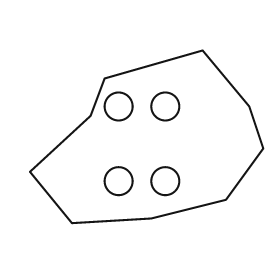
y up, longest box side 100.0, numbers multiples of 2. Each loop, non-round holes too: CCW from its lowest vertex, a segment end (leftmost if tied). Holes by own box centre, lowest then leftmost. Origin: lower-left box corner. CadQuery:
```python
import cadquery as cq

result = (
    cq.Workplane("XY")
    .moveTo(18.0, 0.0)
    .lineTo(52.0, 2.0)
    .lineTo(84.0, 10.0)
    .lineTo(100.0, 32.0)
    .lineTo(94.0, 50.0)
    .lineTo(74.0, 74.0)
    .lineTo(32.0, 62.0)
    .lineTo(26.0, 46.0)
    .lineTo(0.0, 22.0)
    .close()
    .moveTo(38.0, 18.0)
    .circle(6.0)
    .moveTo(58.0, 18.0)
    .circle(6.0)
    .moveTo(38.0, 50.0)
    .circle(6.0)
    .moveTo(58.0, 50.0)
    .circle(6.0)
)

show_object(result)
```